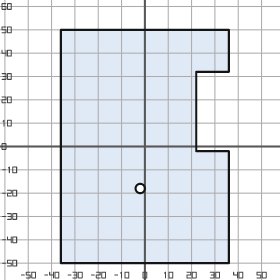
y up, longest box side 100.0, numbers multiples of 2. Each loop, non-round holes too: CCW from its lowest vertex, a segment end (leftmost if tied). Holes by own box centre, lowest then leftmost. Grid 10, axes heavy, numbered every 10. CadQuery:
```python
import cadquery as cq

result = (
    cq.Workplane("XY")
    .moveTo(-36.0, -50.0)
    .lineTo(36.0, -50.0)
    .lineTo(36.0, -2.0)
    .lineTo(22.0, -2.0)
    .lineTo(22.0, 32.0)
    .lineTo(36.0, 32.0)
    .lineTo(36.0, 50.0)
    .lineTo(-36.0, 50.0)
    .close()
    .moveTo(-2.0, -18.0)
    .circle(2.0)
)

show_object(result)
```